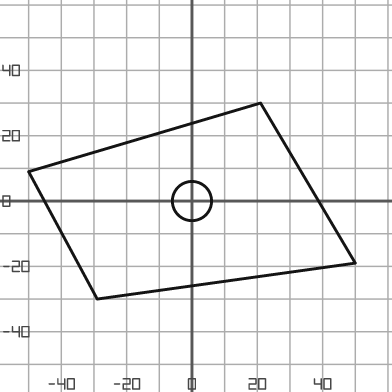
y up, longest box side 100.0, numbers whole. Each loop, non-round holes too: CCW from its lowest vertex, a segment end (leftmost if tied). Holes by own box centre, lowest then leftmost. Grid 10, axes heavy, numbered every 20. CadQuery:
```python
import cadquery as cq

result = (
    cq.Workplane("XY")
    .moveTo(-29.0, -30.0)
    .lineTo(50.0, -19.0)
    .lineTo(21.0, 30.0)
    .lineTo(-50.0, 9.0)
    .close()
    .moveTo(0.0, 0.0)
    .circle(6.0)
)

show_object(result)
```